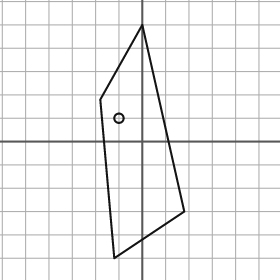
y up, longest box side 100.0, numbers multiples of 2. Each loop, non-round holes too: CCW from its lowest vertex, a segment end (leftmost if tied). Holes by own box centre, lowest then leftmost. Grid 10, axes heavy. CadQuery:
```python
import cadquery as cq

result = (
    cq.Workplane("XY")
    .moveTo(-12.0, -50.0)
    .lineTo(18.0, -30.0)
    .lineTo(0.0, 50.0)
    .lineTo(-18.0, 18.0)
    .close()
    .moveTo(-10.0, 10.0)
    .circle(2.0)
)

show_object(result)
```